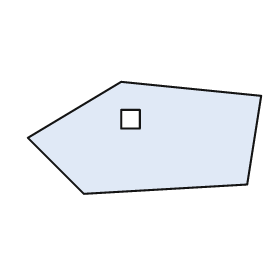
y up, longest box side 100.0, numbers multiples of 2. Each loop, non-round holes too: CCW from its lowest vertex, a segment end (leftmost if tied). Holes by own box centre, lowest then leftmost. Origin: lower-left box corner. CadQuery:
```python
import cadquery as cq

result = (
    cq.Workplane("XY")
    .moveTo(24.0, 0.0)
    .lineTo(94.0, 4.0)
    .lineTo(100.0, 42.0)
    .lineTo(40.0, 48.0)
    .lineTo(0.0, 24.0)
    .close()
    .moveTo(40.0, 28.0)
    .lineTo(48.0, 28.0)
    .lineTo(48.0, 36.0)
    .lineTo(40.0, 36.0)
    .close()
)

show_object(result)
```